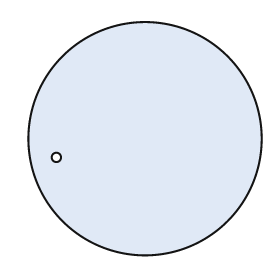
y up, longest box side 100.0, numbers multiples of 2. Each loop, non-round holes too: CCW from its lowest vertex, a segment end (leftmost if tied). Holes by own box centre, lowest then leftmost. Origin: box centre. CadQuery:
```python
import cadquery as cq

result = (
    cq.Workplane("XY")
    .moveTo(0.0, 0.0)
    .circle(50.0)
    .moveTo(-38.0, -8.0)
    .circle(2.0)
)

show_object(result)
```